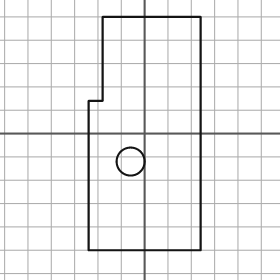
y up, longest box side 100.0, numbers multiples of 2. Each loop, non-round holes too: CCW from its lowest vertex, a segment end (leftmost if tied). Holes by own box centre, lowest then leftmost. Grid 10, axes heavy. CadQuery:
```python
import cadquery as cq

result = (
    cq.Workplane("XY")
    .moveTo(-24.0, -50.0)
    .lineTo(24.0, -50.0)
    .lineTo(24.0, 50.0)
    .lineTo(-18.0, 50.0)
    .lineTo(-18.0, 14.0)
    .lineTo(-24.0, 14.0)
    .close()
    .moveTo(-6.0, -12.0)
    .circle(6.0)
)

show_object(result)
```